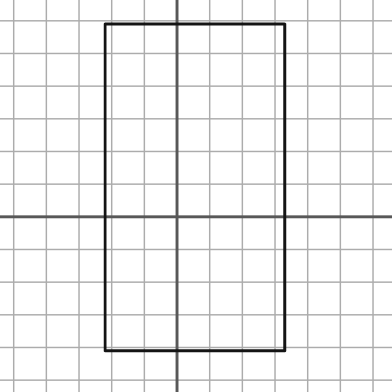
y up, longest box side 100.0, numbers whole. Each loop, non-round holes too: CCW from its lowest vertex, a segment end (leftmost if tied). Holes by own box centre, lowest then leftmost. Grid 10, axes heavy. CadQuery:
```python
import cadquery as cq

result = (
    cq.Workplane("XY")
    .moveTo(-22.0, -41.0)
    .lineTo(33.0, -41.0)
    .lineTo(33.0, 59.0)
    .lineTo(-22.0, 59.0)
    .close()
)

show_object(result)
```